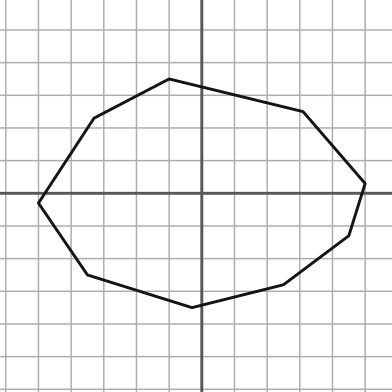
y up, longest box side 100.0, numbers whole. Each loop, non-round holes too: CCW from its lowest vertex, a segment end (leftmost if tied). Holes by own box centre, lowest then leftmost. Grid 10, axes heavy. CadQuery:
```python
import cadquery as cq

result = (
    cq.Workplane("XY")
    .moveTo(-3.0, -35.0)
    .lineTo(25.0, -28.0)
    .lineTo(45.0, -13.0)
    .lineTo(50.0, 3.0)
    .lineTo(31.0, 25.0)
    .lineTo(-10.0, 35.0)
    .lineTo(-33.0, 23.0)
    .lineTo(-50.0, -3.0)
    .lineTo(-35.0, -25.0)
    .close()
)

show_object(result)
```